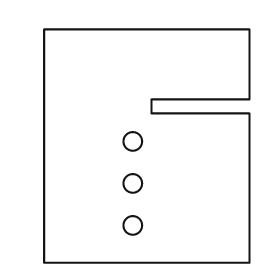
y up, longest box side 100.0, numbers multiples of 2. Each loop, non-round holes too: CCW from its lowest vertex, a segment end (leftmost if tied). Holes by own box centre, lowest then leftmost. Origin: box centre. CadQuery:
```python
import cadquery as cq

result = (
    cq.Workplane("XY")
    .moveTo(-44.0, -50.0)
    .lineTo(44.0, -50.0)
    .lineTo(44.0, 14.0)
    .lineTo(2.0, 14.0)
    .lineTo(2.0, 20.0)
    .lineTo(44.0, 20.0)
    .lineTo(44.0, 50.0)
    .lineTo(-44.0, 50.0)
    .close()
    .moveTo(-6.0, -34.0)
    .circle(4.0)
    .moveTo(-6.0, -16.0)
    .circle(4.0)
    .moveTo(-6.0, 2.0)
    .circle(4.0)
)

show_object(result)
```